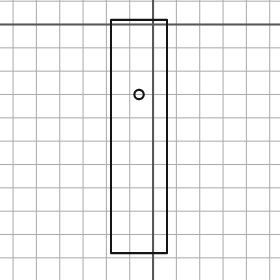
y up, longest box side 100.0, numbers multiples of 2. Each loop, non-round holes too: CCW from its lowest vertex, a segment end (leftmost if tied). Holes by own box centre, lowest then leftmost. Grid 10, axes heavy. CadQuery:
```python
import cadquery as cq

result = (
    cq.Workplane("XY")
    .moveTo(-18.0, -98.0)
    .lineTo(6.0, -98.0)
    .lineTo(6.0, 2.0)
    .lineTo(-18.0, 2.0)
    .close()
    .moveTo(-6.0, -30.0)
    .circle(2.0)
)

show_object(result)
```